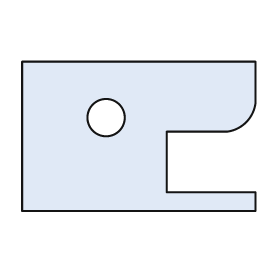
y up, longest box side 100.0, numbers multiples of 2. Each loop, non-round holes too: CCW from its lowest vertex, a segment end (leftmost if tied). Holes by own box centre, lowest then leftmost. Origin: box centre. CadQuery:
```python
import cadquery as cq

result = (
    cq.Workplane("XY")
    .moveTo(-50.0, -32.0)
    .lineTo(50.0, -32.0)
    .lineTo(50.0, -24.0)
    .lineTo(12.0, -24.0)
    .lineTo(12.0, 2.0)
    .lineTo(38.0, 2.0)
    .threePointArc((46.0, 6.0), (50.0, 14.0))
    .lineTo(50.0, 32.0)
    .lineTo(-50.0, 32.0)
    .close()
    .moveTo(-14.0, 8.0)
    .circle(8.0)
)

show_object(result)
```